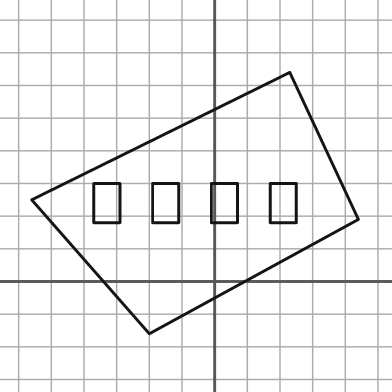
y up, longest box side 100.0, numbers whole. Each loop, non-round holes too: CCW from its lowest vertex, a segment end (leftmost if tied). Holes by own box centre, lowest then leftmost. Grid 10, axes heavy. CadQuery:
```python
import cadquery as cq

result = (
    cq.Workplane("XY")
    .moveTo(-20.0, -16.0)
    .lineTo(44.0, 19.0)
    .lineTo(23.0, 64.0)
    .lineTo(-56.0, 25.0)
    .close()
    .moveTo(-37.0, 18.0)
    .lineTo(-29.0, 18.0)
    .lineTo(-29.0, 30.0)
    .lineTo(-37.0, 30.0)
    .close()
    .moveTo(-19.0, 18.0)
    .lineTo(-11.0, 18.0)
    .lineTo(-11.0, 30.0)
    .lineTo(-19.0, 30.0)
    .close()
    .moveTo(-1.0, 18.0)
    .lineTo(7.0, 18.0)
    .lineTo(7.0, 30.0)
    .lineTo(-1.0, 30.0)
    .close()
    .moveTo(17.0, 18.0)
    .lineTo(25.0, 18.0)
    .lineTo(25.0, 30.0)
    .lineTo(17.0, 30.0)
    .close()
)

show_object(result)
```